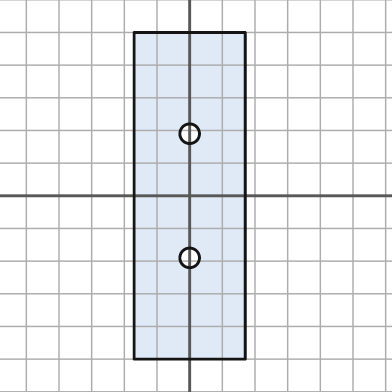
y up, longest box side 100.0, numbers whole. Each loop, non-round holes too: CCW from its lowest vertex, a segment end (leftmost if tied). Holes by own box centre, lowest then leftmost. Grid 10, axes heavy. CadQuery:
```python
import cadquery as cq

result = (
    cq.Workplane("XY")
    .moveTo(-17.0, -50.0)
    .lineTo(17.0, -50.0)
    .lineTo(17.0, 50.0)
    .lineTo(-17.0, 50.0)
    .close()
    .moveTo(0.0, -19.0)
    .circle(3.0)
    .moveTo(0.0, 19.0)
    .circle(3.0)
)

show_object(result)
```